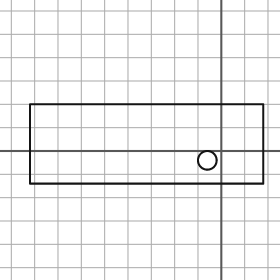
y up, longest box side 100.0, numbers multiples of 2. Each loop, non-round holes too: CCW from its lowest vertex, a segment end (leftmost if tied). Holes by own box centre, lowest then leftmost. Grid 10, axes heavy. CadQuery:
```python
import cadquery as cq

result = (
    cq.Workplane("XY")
    .moveTo(-82.0, -14.0)
    .lineTo(18.0, -14.0)
    .lineTo(18.0, 20.0)
    .lineTo(-82.0, 20.0)
    .close()
    .moveTo(-6.0, -4.0)
    .circle(4.0)
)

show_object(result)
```